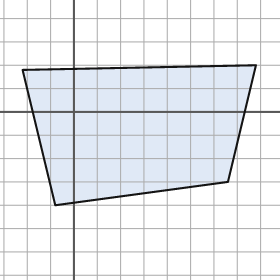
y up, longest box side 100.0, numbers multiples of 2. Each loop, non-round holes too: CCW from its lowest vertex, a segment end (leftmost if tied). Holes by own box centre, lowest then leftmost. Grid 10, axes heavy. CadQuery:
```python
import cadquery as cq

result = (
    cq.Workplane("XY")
    .moveTo(-8.0, -40.0)
    .lineTo(66.0, -30.0)
    .lineTo(78.0, 20.0)
    .lineTo(-22.0, 18.0)
    .close()
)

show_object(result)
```